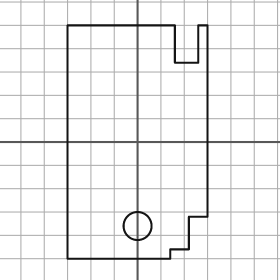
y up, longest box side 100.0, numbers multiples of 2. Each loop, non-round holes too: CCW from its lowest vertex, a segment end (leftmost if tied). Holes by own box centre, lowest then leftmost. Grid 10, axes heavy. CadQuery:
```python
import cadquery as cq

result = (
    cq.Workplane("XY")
    .moveTo(-30.0, -50.0)
    .lineTo(14.0, -50.0)
    .lineTo(14.0, -46.0)
    .lineTo(22.0, -46.0)
    .lineTo(22.0, -32.0)
    .lineTo(30.0, -32.0)
    .lineTo(30.0, 50.0)
    .lineTo(26.0, 50.0)
    .lineTo(26.0, 34.0)
    .lineTo(16.0, 34.0)
    .lineTo(16.0, 50.0)
    .lineTo(-30.0, 50.0)
    .close()
    .moveTo(0.0, -36.0)
    .circle(6.0)
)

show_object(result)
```